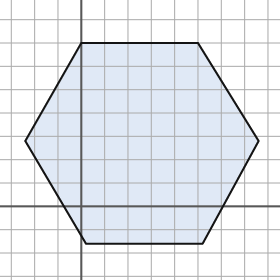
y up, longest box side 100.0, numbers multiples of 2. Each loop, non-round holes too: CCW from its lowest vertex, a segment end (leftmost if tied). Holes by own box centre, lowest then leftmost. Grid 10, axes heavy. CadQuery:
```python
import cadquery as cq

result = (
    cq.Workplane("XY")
    .moveTo(2.0, -16.0)
    .lineTo(52.0, -16.0)
    .lineTo(76.0, 28.0)
    .lineTo(50.0, 70.0)
    .lineTo(0.0, 70.0)
    .lineTo(-24.0, 28.0)
    .close()
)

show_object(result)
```